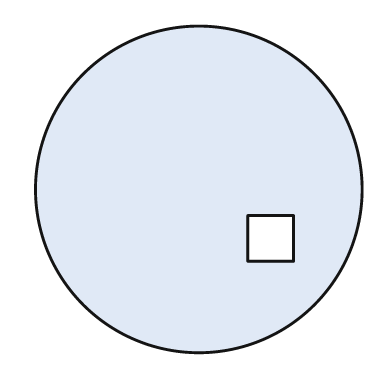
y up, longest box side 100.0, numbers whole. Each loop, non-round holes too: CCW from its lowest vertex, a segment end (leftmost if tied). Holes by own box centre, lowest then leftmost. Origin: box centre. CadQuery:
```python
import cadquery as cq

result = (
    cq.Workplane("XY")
    .moveTo(0.0, 0.0)
    .circle(50.0)
    .moveTo(15.0, -22.0)
    .lineTo(29.0, -22.0)
    .lineTo(29.0, -8.0)
    .lineTo(15.0, -8.0)
    .close()
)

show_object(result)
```